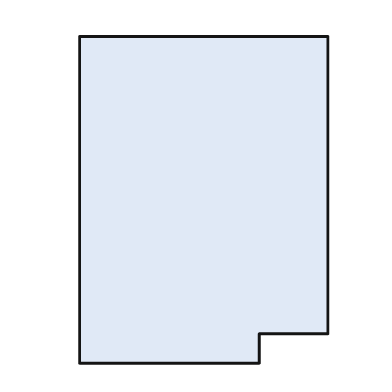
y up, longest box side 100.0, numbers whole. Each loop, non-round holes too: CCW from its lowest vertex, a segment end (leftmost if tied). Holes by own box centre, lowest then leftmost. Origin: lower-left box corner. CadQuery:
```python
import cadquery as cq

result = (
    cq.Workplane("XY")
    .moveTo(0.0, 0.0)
    .lineTo(55.0, 0.0)
    .lineTo(55.0, 9.0)
    .lineTo(76.0, 9.0)
    .lineTo(76.0, 100.0)
    .lineTo(0.0, 100.0)
    .close()
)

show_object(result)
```